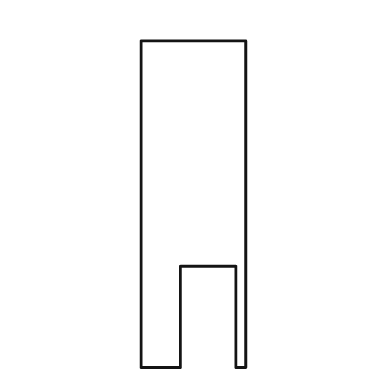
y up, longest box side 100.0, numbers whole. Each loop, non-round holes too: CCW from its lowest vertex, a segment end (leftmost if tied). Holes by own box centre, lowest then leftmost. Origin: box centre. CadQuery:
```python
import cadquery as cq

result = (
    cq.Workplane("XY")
    .moveTo(-16.0, -50.0)
    .lineTo(-4.0, -50.0)
    .lineTo(-4.0, -19.0)
    .lineTo(13.0, -19.0)
    .lineTo(13.0, -50.0)
    .lineTo(16.0, -50.0)
    .lineTo(16.0, 50.0)
    .lineTo(-16.0, 50.0)
    .close()
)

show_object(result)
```